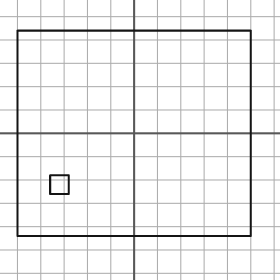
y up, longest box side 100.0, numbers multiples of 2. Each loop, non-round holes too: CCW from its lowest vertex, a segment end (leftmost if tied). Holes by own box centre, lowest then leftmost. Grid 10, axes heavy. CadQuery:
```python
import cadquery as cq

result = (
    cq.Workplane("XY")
    .moveTo(-50.0, -44.0)
    .lineTo(50.0, -44.0)
    .lineTo(50.0, 44.0)
    .lineTo(-50.0, 44.0)
    .close()
    .moveTo(-36.0, -26.0)
    .lineTo(-28.0, -26.0)
    .lineTo(-28.0, -18.0)
    .lineTo(-36.0, -18.0)
    .close()
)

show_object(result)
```